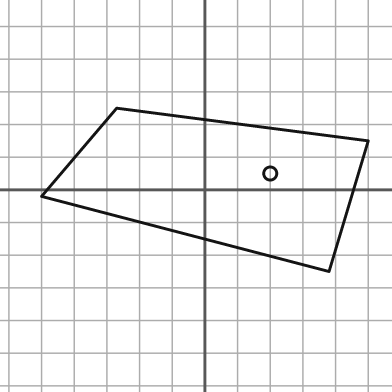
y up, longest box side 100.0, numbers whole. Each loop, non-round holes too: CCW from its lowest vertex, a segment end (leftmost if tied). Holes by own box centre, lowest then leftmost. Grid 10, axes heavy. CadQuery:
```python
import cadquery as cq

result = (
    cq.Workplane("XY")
    .moveTo(38.0, -25.0)
    .lineTo(50.0, 15.0)
    .lineTo(-27.0, 25.0)
    .lineTo(-50.0, -2.0)
    .close()
    .moveTo(20.0, 5.0)
    .circle(2.0)
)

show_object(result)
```